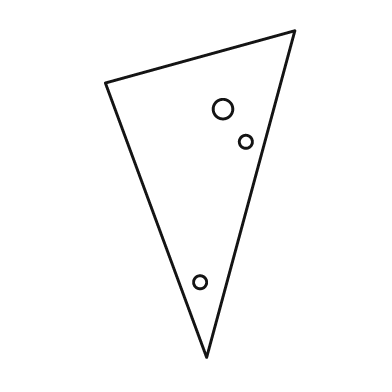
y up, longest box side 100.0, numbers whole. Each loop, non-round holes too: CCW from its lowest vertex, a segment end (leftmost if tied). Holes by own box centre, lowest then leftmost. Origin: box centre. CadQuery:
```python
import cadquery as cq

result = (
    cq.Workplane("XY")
    .moveTo(2.0, -50.0)
    .lineTo(29.0, 50.0)
    .lineTo(-29.0, 34.0)
    .close()
    .moveTo(0.0, -27.0)
    .circle(2.0)
    .moveTo(14.0, 16.0)
    .circle(2.0)
    .moveTo(7.0, 26.0)
    .circle(3.0)
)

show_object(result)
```